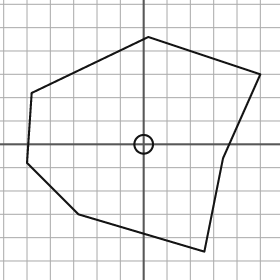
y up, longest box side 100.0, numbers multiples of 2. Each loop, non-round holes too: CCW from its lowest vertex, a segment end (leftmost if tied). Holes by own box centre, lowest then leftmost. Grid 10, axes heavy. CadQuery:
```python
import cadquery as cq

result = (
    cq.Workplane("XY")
    .moveTo(26.0, -46.0)
    .lineTo(34.0, -6.0)
    .lineTo(50.0, 30.0)
    .lineTo(2.0, 46.0)
    .lineTo(-48.0, 22.0)
    .lineTo(-50.0, -8.0)
    .lineTo(-28.0, -30.0)
    .close()
    .moveTo(0.0, 0.0)
    .circle(4.0)
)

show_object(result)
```